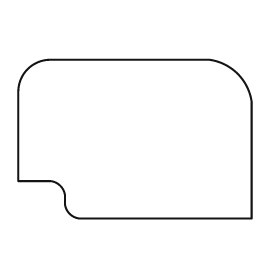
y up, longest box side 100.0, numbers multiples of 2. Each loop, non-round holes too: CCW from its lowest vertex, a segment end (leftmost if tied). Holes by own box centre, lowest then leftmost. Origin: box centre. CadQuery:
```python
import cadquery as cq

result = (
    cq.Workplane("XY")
    .moveTo(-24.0, -34.0)
    .lineTo(50.0, -34.0)
    .lineTo(50.0, 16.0)
    .threePointArc((44.0, 28.0), (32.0, 34.0))
    .lineTo(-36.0, 34.0)
    .threePointArc((-46.0, 30.0), (-50.0, 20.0))
    .lineTo(-50.0, -18.0)
    .lineTo(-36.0, -18.0)
    .threePointArc((-32.0, -20.0), (-30.0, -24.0))
    .lineTo(-30.0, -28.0)
    .threePointArc((-28.0, -32.0), (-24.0, -34.0))
    .close()
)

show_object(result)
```